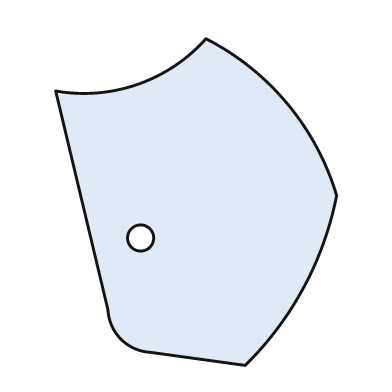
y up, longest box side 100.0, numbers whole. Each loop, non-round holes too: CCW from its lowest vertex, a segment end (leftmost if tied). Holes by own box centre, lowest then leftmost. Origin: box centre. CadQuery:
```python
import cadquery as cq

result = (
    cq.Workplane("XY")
    .moveTo(15.0, -50.0)
    .threePointArc((33.0, -26.0), (43.0, 2.0))
    .threePointArc((28.0, 30.0), (3.0, 50.0))
    .threePointArc((-18.0, 36.0), (-43.0, 34.0))
    .lineTo(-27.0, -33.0)
    .threePointArc((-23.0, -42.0), (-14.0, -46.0))
    .close()
    .moveTo(-17.0, -11.0)
    .circle(4.0)
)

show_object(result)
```